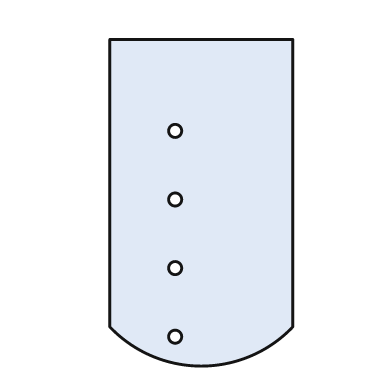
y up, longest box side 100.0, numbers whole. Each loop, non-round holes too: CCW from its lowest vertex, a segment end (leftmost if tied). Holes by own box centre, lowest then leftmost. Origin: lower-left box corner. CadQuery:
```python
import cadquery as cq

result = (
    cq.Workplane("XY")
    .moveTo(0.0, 12.0)
    .threePointArc((28.0, 0.0), (56.0, 12.0))
    .lineTo(56.0, 100.0)
    .lineTo(0.0, 100.0)
    .close()
    .moveTo(20.0, 9.0)
    .circle(2.0)
    .moveTo(20.0, 30.0)
    .circle(2.0)
    .moveTo(20.0, 51.0)
    .circle(2.0)
    .moveTo(20.0, 72.0)
    .circle(2.0)
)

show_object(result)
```